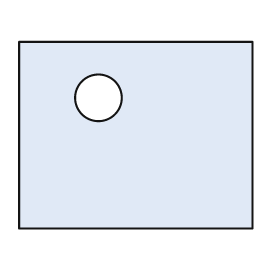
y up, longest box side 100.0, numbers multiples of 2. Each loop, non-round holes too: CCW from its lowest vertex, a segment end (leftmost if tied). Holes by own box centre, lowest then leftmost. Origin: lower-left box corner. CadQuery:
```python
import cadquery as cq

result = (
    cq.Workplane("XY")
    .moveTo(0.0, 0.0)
    .lineTo(100.0, 0.0)
    .lineTo(100.0, 80.0)
    .lineTo(0.0, 80.0)
    .close()
    .moveTo(34.0, 56.0)
    .circle(10.0)
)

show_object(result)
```